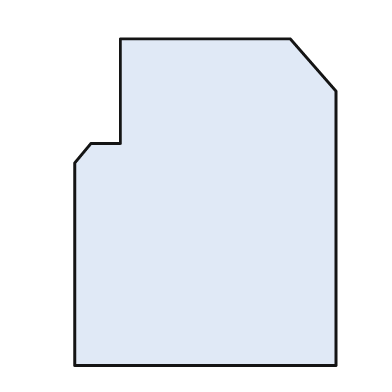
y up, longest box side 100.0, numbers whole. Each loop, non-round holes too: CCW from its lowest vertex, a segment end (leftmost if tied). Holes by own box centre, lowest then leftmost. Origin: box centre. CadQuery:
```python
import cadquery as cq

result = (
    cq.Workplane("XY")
    .moveTo(-40.0, -50.0)
    .lineTo(40.0, -50.0)
    .lineTo(40.0, 34.0)
    .lineTo(26.0, 50.0)
    .lineTo(-26.0, 50.0)
    .lineTo(-26.0, 18.0)
    .lineTo(-35.0, 18.0)
    .lineTo(-40.0, 12.0)
    .close()
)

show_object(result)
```